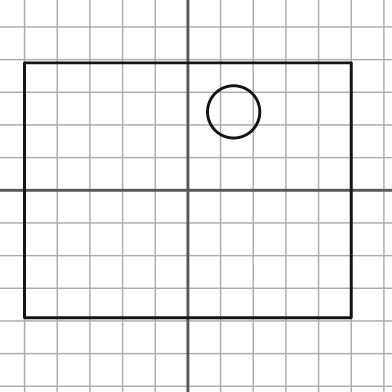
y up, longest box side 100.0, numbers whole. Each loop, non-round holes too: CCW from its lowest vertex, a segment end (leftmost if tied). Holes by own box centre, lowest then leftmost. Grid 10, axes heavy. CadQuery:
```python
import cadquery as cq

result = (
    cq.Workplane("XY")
    .moveTo(-50.0, -39.0)
    .lineTo(50.0, -39.0)
    .lineTo(50.0, 39.0)
    .lineTo(-50.0, 39.0)
    .close()
    .moveTo(14.0, 24.0)
    .circle(8.0)
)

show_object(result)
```